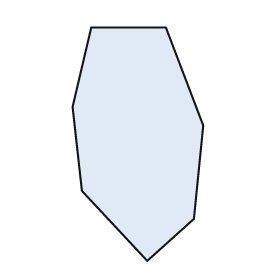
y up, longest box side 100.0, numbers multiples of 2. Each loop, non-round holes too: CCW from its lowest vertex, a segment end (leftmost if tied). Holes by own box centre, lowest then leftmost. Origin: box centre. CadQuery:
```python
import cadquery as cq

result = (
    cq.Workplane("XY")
    .moveTo(4.0, -50.0)
    .lineTo(24.0, -32.0)
    .lineTo(28.0, 8.0)
    .lineTo(12.0, 50.0)
    .lineTo(-20.0, 50.0)
    .lineTo(-28.0, 16.0)
    .lineTo(-24.0, -20.0)
    .close()
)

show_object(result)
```